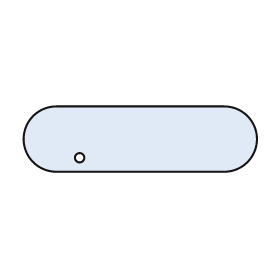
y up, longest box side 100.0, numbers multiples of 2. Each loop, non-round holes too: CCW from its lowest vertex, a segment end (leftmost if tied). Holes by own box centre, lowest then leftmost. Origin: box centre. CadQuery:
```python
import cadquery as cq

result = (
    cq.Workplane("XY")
    .moveTo(-36.0, -14.0)
    .lineTo(36.0, -14.0)
    .threePointArc((50.0, 0.0), (36.0, 14.0))
    .lineTo(-36.0, 14.0)
    .threePointArc((-50.0, 0.0), (-36.0, -14.0))
    .close()
    .moveTo(-26.0, -8.0)
    .circle(2.0)
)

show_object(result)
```